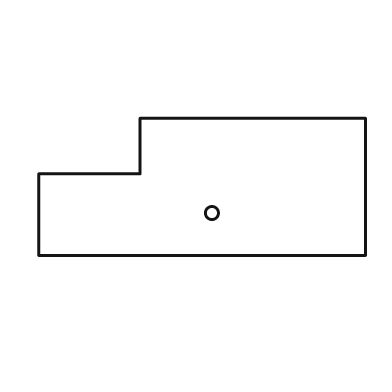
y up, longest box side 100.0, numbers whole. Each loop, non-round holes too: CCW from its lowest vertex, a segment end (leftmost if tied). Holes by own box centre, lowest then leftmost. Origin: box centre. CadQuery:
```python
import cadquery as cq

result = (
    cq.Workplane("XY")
    .moveTo(-50.0, -21.0)
    .lineTo(50.0, -21.0)
    .lineTo(50.0, 21.0)
    .lineTo(-19.0, 21.0)
    .lineTo(-19.0, 4.0)
    .lineTo(-50.0, 4.0)
    .close()
    .moveTo(3.0, -8.0)
    .circle(2.0)
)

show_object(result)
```